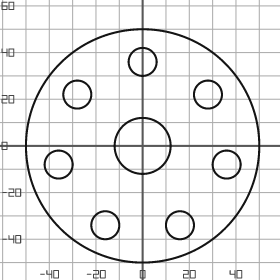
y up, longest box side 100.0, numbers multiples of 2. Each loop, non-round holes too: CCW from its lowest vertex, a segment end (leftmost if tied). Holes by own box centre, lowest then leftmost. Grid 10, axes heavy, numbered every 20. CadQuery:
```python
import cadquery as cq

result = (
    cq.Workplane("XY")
    .moveTo(0.0, 0.0)
    .circle(50.0)
    .moveTo(-16.0, -34.0)
    .circle(6.0)
    .moveTo(16.0, -34.0)
    .circle(6.0)
    .moveTo(-36.0, -8.0)
    .circle(6.0)
    .moveTo(36.0, -8.0)
    .circle(6.0)
    .moveTo(0.0, 0.0)
    .circle(12.0)
    .moveTo(-28.0, 22.0)
    .circle(6.0)
    .moveTo(28.0, 22.0)
    .circle(6.0)
    .moveTo(0.0, 36.0)
    .circle(6.0)
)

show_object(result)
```